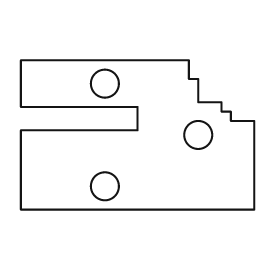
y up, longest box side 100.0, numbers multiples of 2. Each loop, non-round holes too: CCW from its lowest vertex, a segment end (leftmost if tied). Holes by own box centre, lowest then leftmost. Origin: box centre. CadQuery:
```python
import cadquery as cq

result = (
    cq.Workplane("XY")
    .moveTo(-50.0, -32.0)
    .lineTo(50.0, -32.0)
    .lineTo(50.0, 6.0)
    .lineTo(40.0, 6.0)
    .lineTo(40.0, 10.0)
    .lineTo(36.0, 10.0)
    .lineTo(36.0, 14.0)
    .lineTo(26.0, 14.0)
    .lineTo(26.0, 24.0)
    .lineTo(22.0, 24.0)
    .lineTo(22.0, 32.0)
    .lineTo(-50.0, 32.0)
    .lineTo(-50.0, 12.0)
    .lineTo(0.0, 12.0)
    .lineTo(0.0, 2.0)
    .lineTo(-50.0, 2.0)
    .close()
    .moveTo(-14.0, -22.0)
    .circle(6.0)
    .moveTo(26.0, 0.0)
    .circle(6.0)
    .moveTo(-14.0, 22.0)
    .circle(6.0)
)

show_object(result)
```